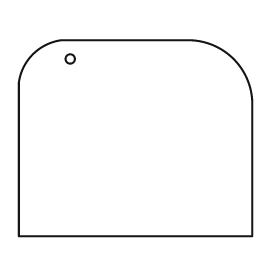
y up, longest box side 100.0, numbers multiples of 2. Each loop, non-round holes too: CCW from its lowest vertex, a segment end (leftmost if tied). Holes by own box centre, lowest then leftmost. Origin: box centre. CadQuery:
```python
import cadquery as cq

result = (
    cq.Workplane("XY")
    .moveTo(-50.0, -42.0)
    .lineTo(50.0, -42.0)
    .lineTo(50.0, 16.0)
    .threePointArc((42.0, 34.0), (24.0, 42.0))
    .lineTo(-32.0, 42.0)
    .threePointArc((-44.0, 36.0), (-50.0, 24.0))
    .close()
    .moveTo(-28.0, 34.0)
    .circle(2.0)
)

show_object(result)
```